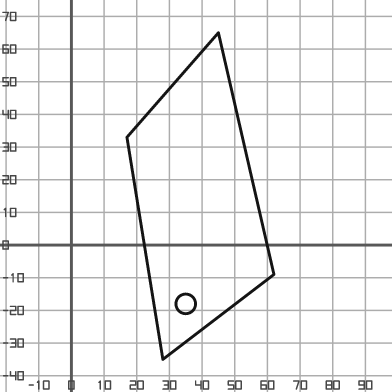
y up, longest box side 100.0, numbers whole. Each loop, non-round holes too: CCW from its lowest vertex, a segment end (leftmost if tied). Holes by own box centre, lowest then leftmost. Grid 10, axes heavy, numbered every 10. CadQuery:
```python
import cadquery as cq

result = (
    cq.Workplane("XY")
    .moveTo(28.0, -35.0)
    .lineTo(62.0, -9.0)
    .lineTo(45.0, 65.0)
    .lineTo(17.0, 33.0)
    .close()
    .moveTo(35.0, -18.0)
    .circle(3.0)
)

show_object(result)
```